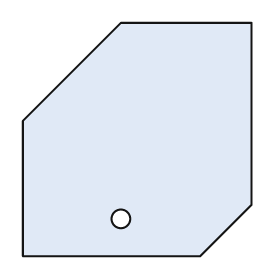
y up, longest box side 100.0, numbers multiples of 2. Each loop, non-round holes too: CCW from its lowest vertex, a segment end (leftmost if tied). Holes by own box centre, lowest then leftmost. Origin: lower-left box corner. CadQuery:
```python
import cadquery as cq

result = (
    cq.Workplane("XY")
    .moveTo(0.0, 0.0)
    .lineTo(76.0, 0.0)
    .lineTo(98.0, 22.0)
    .lineTo(98.0, 100.0)
    .lineTo(42.0, 100.0)
    .lineTo(0.0, 58.0)
    .close()
    .moveTo(42.0, 16.0)
    .circle(4.0)
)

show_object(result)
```